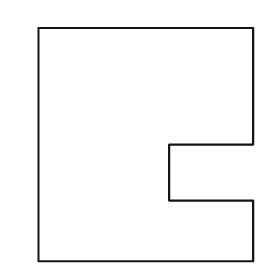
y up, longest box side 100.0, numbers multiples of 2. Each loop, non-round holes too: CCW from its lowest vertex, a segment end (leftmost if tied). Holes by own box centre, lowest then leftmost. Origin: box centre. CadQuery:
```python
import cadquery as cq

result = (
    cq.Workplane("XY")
    .moveTo(-46.0, -50.0)
    .lineTo(46.0, -50.0)
    .lineTo(46.0, -24.0)
    .lineTo(10.0, -24.0)
    .lineTo(10.0, 0.0)
    .lineTo(46.0, 0.0)
    .lineTo(46.0, 50.0)
    .lineTo(-46.0, 50.0)
    .close()
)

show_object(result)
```